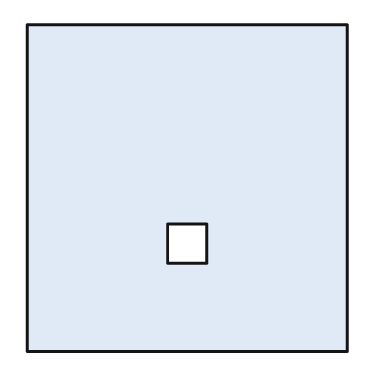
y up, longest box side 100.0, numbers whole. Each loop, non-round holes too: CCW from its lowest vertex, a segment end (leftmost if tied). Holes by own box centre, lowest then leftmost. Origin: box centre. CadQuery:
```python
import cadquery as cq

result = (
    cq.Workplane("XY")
    .moveTo(-49.0, -50.0)
    .lineTo(49.0, -50.0)
    .lineTo(49.0, 50.0)
    .lineTo(-49.0, 50.0)
    .close()
    .moveTo(-6.0, -23.0)
    .lineTo(6.0, -23.0)
    .lineTo(6.0, -11.0)
    .lineTo(-6.0, -11.0)
    .close()
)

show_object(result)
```